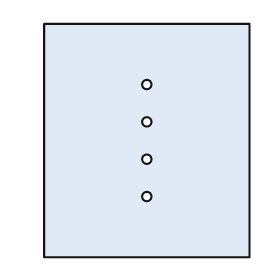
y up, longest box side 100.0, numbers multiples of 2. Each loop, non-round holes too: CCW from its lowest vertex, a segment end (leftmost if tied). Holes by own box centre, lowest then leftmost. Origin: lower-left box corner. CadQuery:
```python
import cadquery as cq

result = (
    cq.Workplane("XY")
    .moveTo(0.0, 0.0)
    .lineTo(88.0, 0.0)
    .lineTo(88.0, 100.0)
    .lineTo(0.0, 100.0)
    .close()
    .moveTo(44.0, 26.0)
    .circle(2.0)
    .moveTo(44.0, 42.0)
    .circle(2.0)
    .moveTo(44.0, 58.0)
    .circle(2.0)
    .moveTo(44.0, 74.0)
    .circle(2.0)
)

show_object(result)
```